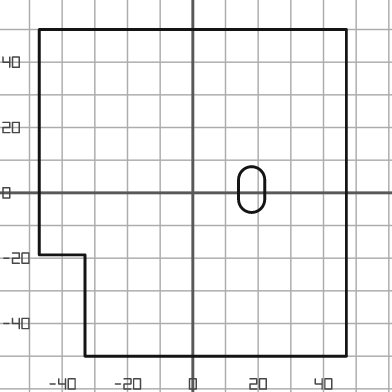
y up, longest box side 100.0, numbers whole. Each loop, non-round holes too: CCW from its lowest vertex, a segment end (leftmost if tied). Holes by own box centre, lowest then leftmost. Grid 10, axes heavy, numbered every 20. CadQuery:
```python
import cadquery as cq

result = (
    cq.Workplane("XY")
    .moveTo(-33.0, -50.0)
    .lineTo(47.0, -50.0)
    .lineTo(47.0, 50.0)
    .lineTo(-47.0, 50.0)
    .lineTo(-47.0, -19.0)
    .lineTo(-33.0, -19.0)
    .close()
    .moveTo(14.0, -2.0)
    .threePointArc((18.0, -6.0), (22.0, -2.0))
    .lineTo(22.0, 4.0)
    .threePointArc((18.0, 8.0), (14.0, 4.0))
    .close()
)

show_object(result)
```